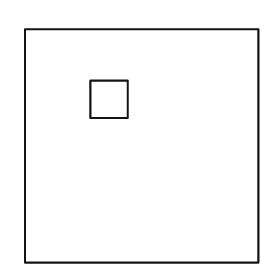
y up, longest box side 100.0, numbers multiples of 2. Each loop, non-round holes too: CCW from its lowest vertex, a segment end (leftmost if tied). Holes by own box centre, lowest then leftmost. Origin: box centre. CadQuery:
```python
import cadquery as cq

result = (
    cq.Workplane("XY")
    .moveTo(-50.0, -50.0)
    .lineTo(50.0, -50.0)
    .lineTo(50.0, 50.0)
    .lineTo(-50.0, 50.0)
    .close()
    .moveTo(-22.0, 12.0)
    .lineTo(-6.0, 12.0)
    .lineTo(-6.0, 28.0)
    .lineTo(-22.0, 28.0)
    .close()
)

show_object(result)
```